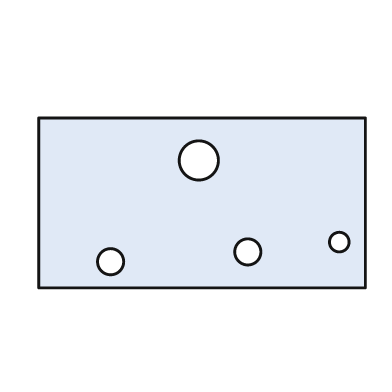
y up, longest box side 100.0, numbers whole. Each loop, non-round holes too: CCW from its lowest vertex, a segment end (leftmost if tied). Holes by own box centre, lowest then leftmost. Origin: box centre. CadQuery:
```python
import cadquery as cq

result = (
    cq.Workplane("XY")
    .moveTo(-50.0, -26.0)
    .lineTo(50.0, -26.0)
    .lineTo(50.0, 26.0)
    .lineTo(-50.0, 26.0)
    .close()
    .moveTo(-28.0, -18.0)
    .circle(4.0)
    .moveTo(14.0, -15.0)
    .circle(4.0)
    .moveTo(42.0, -12.0)
    .circle(3.0)
    .moveTo(-1.0, 13.0)
    .circle(6.0)
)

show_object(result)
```